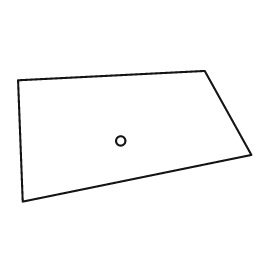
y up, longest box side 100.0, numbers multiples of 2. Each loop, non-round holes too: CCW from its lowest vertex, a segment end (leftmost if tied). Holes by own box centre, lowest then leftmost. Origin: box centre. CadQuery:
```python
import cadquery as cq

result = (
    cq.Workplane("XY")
    .moveTo(-48.0, -28.0)
    .lineTo(50.0, -8.0)
    .lineTo(30.0, 28.0)
    .lineTo(-50.0, 24.0)
    .close()
    .moveTo(-6.0, -2.0)
    .circle(2.0)
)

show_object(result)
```